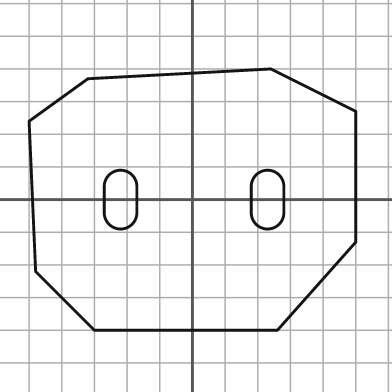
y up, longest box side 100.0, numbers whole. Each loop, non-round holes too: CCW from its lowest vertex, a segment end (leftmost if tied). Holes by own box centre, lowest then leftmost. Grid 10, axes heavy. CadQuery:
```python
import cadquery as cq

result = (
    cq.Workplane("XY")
    .moveTo(-30.0, -40.0)
    .lineTo(26.0, -40.0)
    .lineTo(50.0, -13.0)
    .lineTo(50.0, 27.0)
    .lineTo(24.0, 40.0)
    .lineTo(-32.0, 37.0)
    .lineTo(-50.0, 24.0)
    .lineTo(-48.0, -22.0)
    .close()
    .moveTo(-27.0, -4.0)
    .threePointArc((-22.0, -9.0), (-17.0, -4.0))
    .lineTo(-17.0, 4.0)
    .threePointArc((-22.0, 9.0), (-27.0, 4.0))
    .close()
    .moveTo(18.0, -4.0)
    .threePointArc((23.0, -9.0), (28.0, -4.0))
    .lineTo(28.0, 4.0)
    .threePointArc((23.0, 9.0), (18.0, 4.0))
    .close()
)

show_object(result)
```